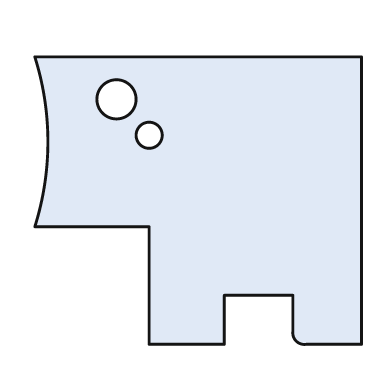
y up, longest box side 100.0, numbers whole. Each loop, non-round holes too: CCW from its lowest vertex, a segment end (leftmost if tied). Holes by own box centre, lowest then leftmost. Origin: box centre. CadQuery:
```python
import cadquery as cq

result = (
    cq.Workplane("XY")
    .moveTo(-15.0, -44.0)
    .lineTo(8.0, -44.0)
    .lineTo(8.0, -29.0)
    .lineTo(29.0, -29.0)
    .lineTo(29.0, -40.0)
    .threePointArc((30.0, -43.0), (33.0, -44.0))
    .lineTo(50.0, -44.0)
    .lineTo(50.0, 44.0)
    .lineTo(-50.0, 44.0)
    .threePointArc((-46.0, 18.0), (-50.0, -8.0))
    .lineTo(-15.0, -8.0)
    .close()
    .moveTo(-15.0, 20.0)
    .circle(4.0)
    .moveTo(-25.0, 31.0)
    .circle(6.0)
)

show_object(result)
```